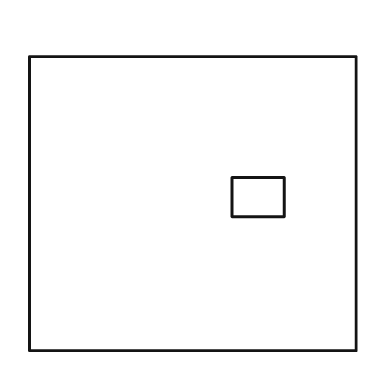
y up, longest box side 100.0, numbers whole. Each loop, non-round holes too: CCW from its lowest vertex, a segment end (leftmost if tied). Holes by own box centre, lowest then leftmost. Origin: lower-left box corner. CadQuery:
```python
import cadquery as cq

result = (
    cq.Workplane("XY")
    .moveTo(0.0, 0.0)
    .lineTo(100.0, 0.0)
    .lineTo(100.0, 90.0)
    .lineTo(0.0, 90.0)
    .close()
    .moveTo(62.0, 41.0)
    .lineTo(78.0, 41.0)
    .lineTo(78.0, 53.0)
    .lineTo(62.0, 53.0)
    .close()
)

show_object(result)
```